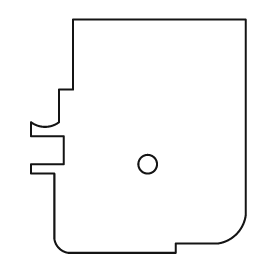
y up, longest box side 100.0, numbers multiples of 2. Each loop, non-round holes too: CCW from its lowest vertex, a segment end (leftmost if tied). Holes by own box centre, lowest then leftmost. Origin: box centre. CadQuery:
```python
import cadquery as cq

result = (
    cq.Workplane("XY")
    .moveTo(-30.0, -50.0)
    .lineTo(16.0, -50.0)
    .lineTo(16.0, -46.0)
    .lineTo(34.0, -46.0)
    .threePointArc((42.0, -42.0), (46.0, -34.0))
    .lineTo(46.0, 50.0)
    .lineTo(-28.0, 50.0)
    .lineTo(-28.0, 20.0)
    .lineTo(-34.0, 20.0)
    .lineTo(-34.0, 6.0)
    .threePointArc((-40.0, 4.0), (-46.0, 6.0))
    .lineTo(-46.0, 0.0)
    .lineTo(-32.0, 0.0)
    .lineTo(-32.0, -12.0)
    .lineTo(-46.0, -12.0)
    .lineTo(-46.0, -16.0)
    .lineTo(-36.0, -16.0)
    .lineTo(-36.0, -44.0)
    .threePointArc((-34.0, -48.0), (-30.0, -50.0))
    .close()
    .moveTo(4.0, -12.0)
    .circle(4.0)
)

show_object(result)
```